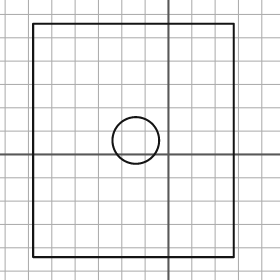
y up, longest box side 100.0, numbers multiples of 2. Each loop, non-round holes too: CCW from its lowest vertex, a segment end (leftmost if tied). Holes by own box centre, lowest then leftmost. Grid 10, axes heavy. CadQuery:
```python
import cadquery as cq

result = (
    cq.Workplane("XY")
    .moveTo(-58.0, -44.0)
    .lineTo(28.0, -44.0)
    .lineTo(28.0, 56.0)
    .lineTo(-58.0, 56.0)
    .close()
    .moveTo(-14.0, 6.0)
    .circle(10.0)
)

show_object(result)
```